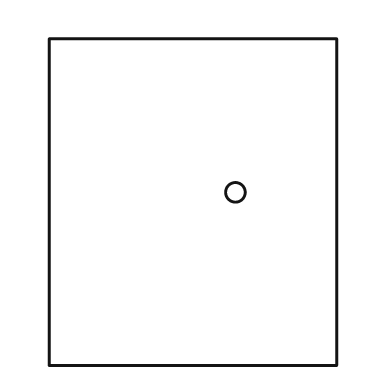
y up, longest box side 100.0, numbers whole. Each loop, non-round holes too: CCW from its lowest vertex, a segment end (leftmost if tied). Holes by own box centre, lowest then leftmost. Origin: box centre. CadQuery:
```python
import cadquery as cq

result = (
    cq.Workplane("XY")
    .moveTo(-44.0, -50.0)
    .lineTo(44.0, -50.0)
    .lineTo(44.0, 50.0)
    .lineTo(-44.0, 50.0)
    .close()
    .moveTo(13.0, 3.0)
    .circle(3.0)
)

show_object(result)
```